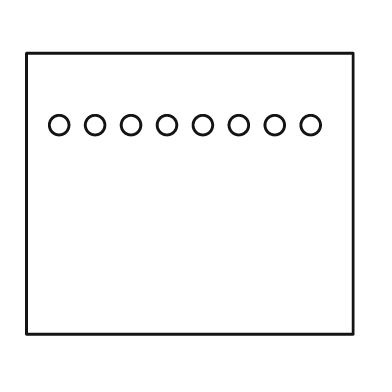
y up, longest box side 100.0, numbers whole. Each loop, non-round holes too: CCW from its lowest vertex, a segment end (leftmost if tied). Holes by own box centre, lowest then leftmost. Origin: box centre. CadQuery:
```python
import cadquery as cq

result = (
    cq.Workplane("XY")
    .moveTo(-50.0, -43.0)
    .lineTo(50.0, -43.0)
    .lineTo(50.0, 43.0)
    .lineTo(-50.0, 43.0)
    .close()
    .moveTo(-40.0, 21.0)
    .circle(3.0)
    .moveTo(-29.0, 21.0)
    .circle(3.0)
    .moveTo(-18.0, 21.0)
    .circle(3.0)
    .moveTo(-7.0, 21.0)
    .circle(3.0)
    .moveTo(4.0, 21.0)
    .circle(3.0)
    .moveTo(15.0, 21.0)
    .circle(3.0)
    .moveTo(26.0, 21.0)
    .circle(3.0)
    .moveTo(37.0, 21.0)
    .circle(3.0)
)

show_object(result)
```